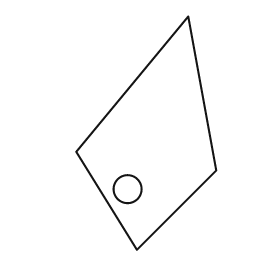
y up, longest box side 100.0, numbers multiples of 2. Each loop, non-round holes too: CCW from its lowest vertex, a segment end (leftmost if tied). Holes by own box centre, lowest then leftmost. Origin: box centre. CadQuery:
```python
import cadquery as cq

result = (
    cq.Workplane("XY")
    .moveTo(-4.0, -50.0)
    .lineTo(30.0, -16.0)
    .lineTo(18.0, 50.0)
    .lineTo(-30.0, -8.0)
    .close()
    .moveTo(-8.0, -24.0)
    .circle(6.0)
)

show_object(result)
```